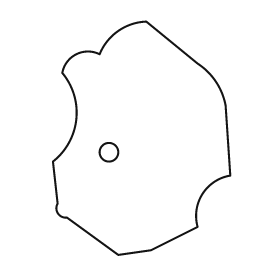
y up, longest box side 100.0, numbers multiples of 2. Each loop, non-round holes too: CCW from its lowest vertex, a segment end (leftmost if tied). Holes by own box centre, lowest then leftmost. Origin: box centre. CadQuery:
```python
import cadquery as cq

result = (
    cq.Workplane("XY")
    .moveTo(-10.0, -50.0)
    .lineTo(4.0, -48.0)
    .lineTo(24.0, -38.0)
    .threePointArc((26.0, -24.0), (38.0, -16.0))
    .lineTo(36.0, 14.0)
    .threePointArc((32.0, 24.0), (24.0, 32.0))
    .lineTo(2.0, 50.0)
    .threePointArc((-10.0, 46.0), (-18.0, 36.0))
    .threePointArc((-28.0, 36.0), (-34.0, 28.0))
    .threePointArc((-28.0, 8.0), (-38.0, -10.0))
    .lineTo(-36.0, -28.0)
    .threePointArc((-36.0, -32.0), (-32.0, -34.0))
    .close()
    .moveTo(-14.0, -6.0)
    .circle(4.0)
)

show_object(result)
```